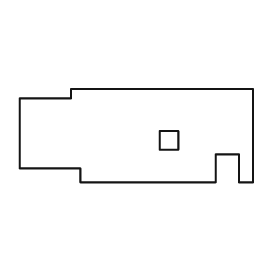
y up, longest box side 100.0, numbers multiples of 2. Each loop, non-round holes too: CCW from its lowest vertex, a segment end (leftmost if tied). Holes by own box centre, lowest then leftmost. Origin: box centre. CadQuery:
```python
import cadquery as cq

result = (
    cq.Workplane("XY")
    .moveTo(-24.0, -20.0)
    .lineTo(34.0, -20.0)
    .lineTo(34.0, -8.0)
    .lineTo(44.0, -8.0)
    .lineTo(44.0, -20.0)
    .lineTo(50.0, -20.0)
    .lineTo(50.0, 20.0)
    .lineTo(-28.0, 20.0)
    .lineTo(-28.0, 16.0)
    .lineTo(-50.0, 16.0)
    .lineTo(-50.0, -14.0)
    .lineTo(-24.0, -14.0)
    .close()
    .moveTo(10.0, -6.0)
    .lineTo(18.0, -6.0)
    .lineTo(18.0, 2.0)
    .lineTo(10.0, 2.0)
    .close()
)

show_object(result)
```